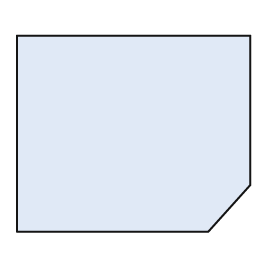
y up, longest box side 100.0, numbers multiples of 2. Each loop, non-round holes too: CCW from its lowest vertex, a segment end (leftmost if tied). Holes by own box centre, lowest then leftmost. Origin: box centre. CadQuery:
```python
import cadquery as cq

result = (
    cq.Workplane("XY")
    .moveTo(-50.0, -42.0)
    .lineTo(32.0, -42.0)
    .lineTo(50.0, -22.0)
    .lineTo(50.0, 42.0)
    .lineTo(-50.0, 42.0)
    .close()
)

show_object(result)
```